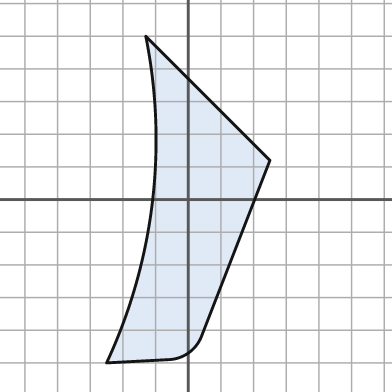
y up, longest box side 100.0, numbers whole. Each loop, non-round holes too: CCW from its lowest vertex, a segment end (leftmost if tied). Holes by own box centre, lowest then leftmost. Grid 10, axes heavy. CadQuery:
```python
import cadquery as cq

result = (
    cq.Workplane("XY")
    .moveTo(-25.0, -50.0)
    .lineTo(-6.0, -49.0)
    .threePointArc((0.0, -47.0), (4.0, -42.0))
    .lineTo(25.0, 12.0)
    .lineTo(-13.0, 50.0)
    .threePointArc((-11.0, -1.0), (-25.0, -50.0))
    .close()
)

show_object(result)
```